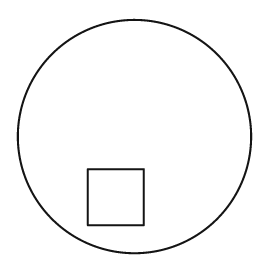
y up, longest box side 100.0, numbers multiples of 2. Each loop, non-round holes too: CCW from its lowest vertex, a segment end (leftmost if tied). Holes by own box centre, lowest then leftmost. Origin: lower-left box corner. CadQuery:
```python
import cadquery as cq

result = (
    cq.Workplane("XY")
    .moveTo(50.0, 50.0)
    .circle(50.0)
    .moveTo(30.0, 12.0)
    .lineTo(54.0, 12.0)
    .lineTo(54.0, 36.0)
    .lineTo(30.0, 36.0)
    .close()
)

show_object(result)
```